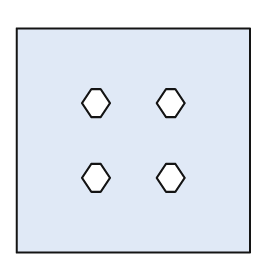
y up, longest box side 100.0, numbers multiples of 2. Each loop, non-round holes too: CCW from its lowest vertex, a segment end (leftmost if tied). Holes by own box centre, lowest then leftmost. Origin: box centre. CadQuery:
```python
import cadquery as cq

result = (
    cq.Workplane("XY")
    .moveTo(-50.0, -48.0)
    .lineTo(50.0, -48.0)
    .lineTo(50.0, 48.0)
    .lineTo(-50.0, 48.0)
    .close()
    .moveTo(-18.0, -22.0)
    .lineTo(-14.0, -22.0)
    .lineTo(-10.0, -16.0)
    .lineTo(-14.0, -10.0)
    .lineTo(-18.0, -10.0)
    .lineTo(-22.0, -16.0)
    .close()
    .moveTo(14.0, -22.0)
    .lineTo(18.0, -22.0)
    .lineTo(22.0, -16.0)
    .lineTo(18.0, -10.0)
    .lineTo(14.0, -10.0)
    .lineTo(10.0, -16.0)
    .close()
    .moveTo(-18.0, 10.0)
    .lineTo(-14.0, 10.0)
    .lineTo(-10.0, 16.0)
    .lineTo(-14.0, 22.0)
    .lineTo(-18.0, 22.0)
    .lineTo(-22.0, 16.0)
    .close()
    .moveTo(14.0, 10.0)
    .lineTo(18.0, 10.0)
    .lineTo(22.0, 16.0)
    .lineTo(18.0, 22.0)
    .lineTo(14.0, 22.0)
    .lineTo(10.0, 16.0)
    .close()
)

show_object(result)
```